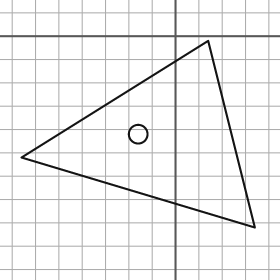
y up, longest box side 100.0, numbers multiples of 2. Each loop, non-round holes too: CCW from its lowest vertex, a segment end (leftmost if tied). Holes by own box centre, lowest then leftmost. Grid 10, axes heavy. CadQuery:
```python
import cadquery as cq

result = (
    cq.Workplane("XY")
    .moveTo(34.0, -82.0)
    .lineTo(14.0, -2.0)
    .lineTo(-66.0, -52.0)
    .close()
    .moveTo(-16.0, -42.0)
    .circle(4.0)
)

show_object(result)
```